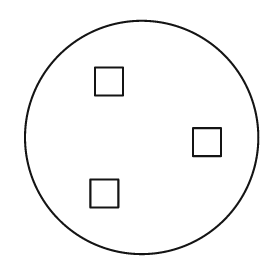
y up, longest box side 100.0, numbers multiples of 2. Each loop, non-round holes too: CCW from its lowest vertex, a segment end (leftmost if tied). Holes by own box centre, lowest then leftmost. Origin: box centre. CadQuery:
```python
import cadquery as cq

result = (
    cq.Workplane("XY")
    .moveTo(0.0, 0.0)
    .circle(50.0)
    .moveTo(-22.0, -30.0)
    .lineTo(-10.0, -30.0)
    .lineTo(-10.0, -18.0)
    .lineTo(-22.0, -18.0)
    .close()
    .moveTo(22.0, -8.0)
    .lineTo(34.0, -8.0)
    .lineTo(34.0, 4.0)
    .lineTo(22.0, 4.0)
    .close()
    .moveTo(-20.0, 18.0)
    .lineTo(-8.0, 18.0)
    .lineTo(-8.0, 30.0)
    .lineTo(-20.0, 30.0)
    .close()
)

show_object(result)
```